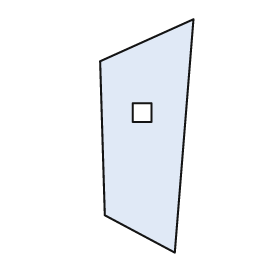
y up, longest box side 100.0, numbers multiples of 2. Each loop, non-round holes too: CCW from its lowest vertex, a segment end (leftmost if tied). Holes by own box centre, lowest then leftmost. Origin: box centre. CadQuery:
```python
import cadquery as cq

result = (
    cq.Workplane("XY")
    .moveTo(12.0, -50.0)
    .lineTo(20.0, 50.0)
    .lineTo(-20.0, 32.0)
    .lineTo(-18.0, -34.0)
    .close()
    .moveTo(-6.0, 6.0)
    .lineTo(2.0, 6.0)
    .lineTo(2.0, 14.0)
    .lineTo(-6.0, 14.0)
    .close()
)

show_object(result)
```